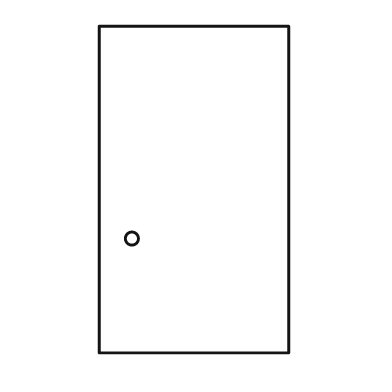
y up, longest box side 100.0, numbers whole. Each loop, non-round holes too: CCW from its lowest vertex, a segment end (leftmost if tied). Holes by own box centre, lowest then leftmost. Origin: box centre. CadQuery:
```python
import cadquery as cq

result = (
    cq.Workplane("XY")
    .moveTo(-29.0, -50.0)
    .lineTo(29.0, -50.0)
    .lineTo(29.0, 50.0)
    .lineTo(-29.0, 50.0)
    .close()
    .moveTo(-19.0, -15.0)
    .circle(2.0)
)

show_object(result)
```